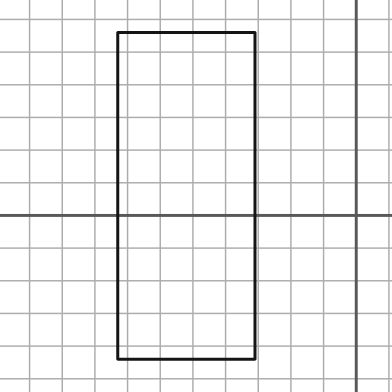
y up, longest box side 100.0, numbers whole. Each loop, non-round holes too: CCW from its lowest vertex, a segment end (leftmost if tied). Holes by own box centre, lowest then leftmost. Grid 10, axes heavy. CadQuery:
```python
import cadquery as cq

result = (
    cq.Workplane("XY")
    .moveTo(-73.0, -44.0)
    .lineTo(-31.0, -44.0)
    .lineTo(-31.0, 56.0)
    .lineTo(-73.0, 56.0)
    .close()
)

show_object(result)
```